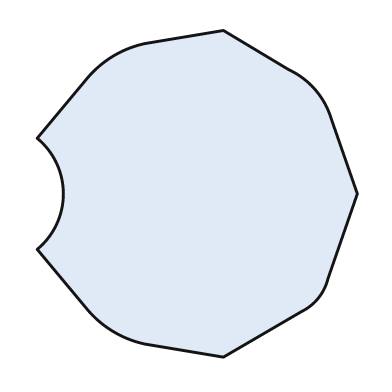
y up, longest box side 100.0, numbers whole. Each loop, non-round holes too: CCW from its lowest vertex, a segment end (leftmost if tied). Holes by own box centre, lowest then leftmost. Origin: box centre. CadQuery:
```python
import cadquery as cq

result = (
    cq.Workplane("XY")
    .moveTo(8.0, -50.0)
    .lineTo(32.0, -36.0)
    .threePointArc((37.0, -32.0), (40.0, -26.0))
    .lineTo(49.0, 0.0)
    .lineTo(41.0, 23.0)
    .threePointArc((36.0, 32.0), (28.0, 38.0))
    .lineTo(8.0, 50.0)
    .lineTo(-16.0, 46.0)
    .threePointArc((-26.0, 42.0), (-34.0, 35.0))
    .lineTo(-49.0, 17.0)
    .threePointArc((-41.0, 0.0), (-49.0, -17.0))
    .lineTo(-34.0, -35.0)
    .threePointArc((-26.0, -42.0), (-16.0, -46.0))
    .close()
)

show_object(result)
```